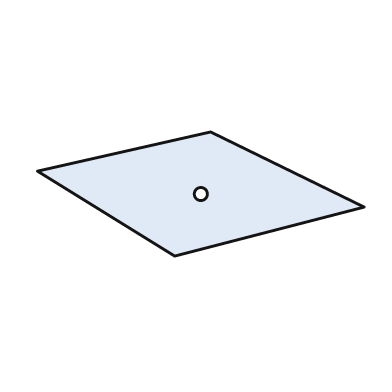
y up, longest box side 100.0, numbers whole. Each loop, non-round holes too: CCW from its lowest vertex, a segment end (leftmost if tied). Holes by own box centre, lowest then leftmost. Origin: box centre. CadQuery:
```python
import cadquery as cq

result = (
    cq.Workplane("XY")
    .moveTo(-8.0, -19.0)
    .lineTo(50.0, -4.0)
    .lineTo(3.0, 19.0)
    .lineTo(-50.0, 7.0)
    .close()
    .moveTo(0.0, 0.0)
    .circle(2.0)
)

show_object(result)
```